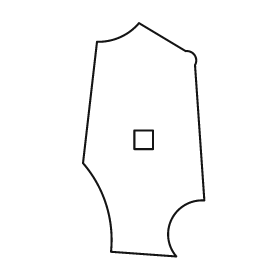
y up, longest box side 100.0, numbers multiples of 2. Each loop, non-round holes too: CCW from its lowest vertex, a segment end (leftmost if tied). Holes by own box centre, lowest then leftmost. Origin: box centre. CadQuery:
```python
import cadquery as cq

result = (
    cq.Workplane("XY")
    .moveTo(14.0, -50.0)
    .threePointArc((12.0, -34.0), (26.0, -26.0))
    .lineTo(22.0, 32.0)
    .threePointArc((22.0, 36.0), (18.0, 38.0))
    .lineTo(-2.0, 50.0)
    .threePointArc((-10.0, 44.0), (-20.0, 42.0))
    .lineTo(-26.0, -10.0)
    .threePointArc((-16.0, -28.0), (-14.0, -48.0))
    .close()
    .moveTo(-4.0, -4.0)
    .lineTo(4.0, -4.0)
    .lineTo(4.0, 4.0)
    .lineTo(-4.0, 4.0)
    .close()
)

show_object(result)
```